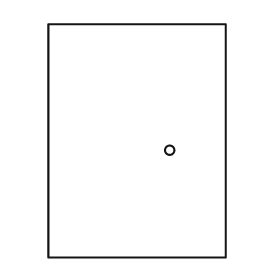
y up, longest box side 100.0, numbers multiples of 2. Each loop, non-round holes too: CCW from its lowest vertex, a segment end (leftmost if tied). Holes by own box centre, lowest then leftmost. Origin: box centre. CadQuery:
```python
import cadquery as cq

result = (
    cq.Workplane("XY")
    .moveTo(-38.0, -50.0)
    .lineTo(38.0, -50.0)
    .lineTo(38.0, 50.0)
    .lineTo(-38.0, 50.0)
    .close()
    .moveTo(14.0, -4.0)
    .circle(2.0)
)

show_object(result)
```